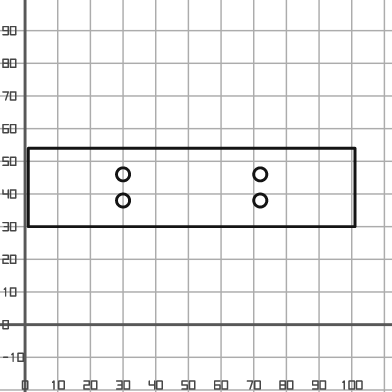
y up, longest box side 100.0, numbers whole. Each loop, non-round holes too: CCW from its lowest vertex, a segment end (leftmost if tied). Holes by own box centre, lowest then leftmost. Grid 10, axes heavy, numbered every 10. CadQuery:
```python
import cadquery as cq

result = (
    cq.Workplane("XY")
    .moveTo(1.0, 30.0)
    .lineTo(101.0, 30.0)
    .lineTo(101.0, 54.0)
    .lineTo(1.0, 54.0)
    .close()
    .moveTo(30.0, 38.0)
    .circle(2.0)
    .moveTo(72.0, 38.0)
    .circle(2.0)
    .moveTo(30.0, 46.0)
    .circle(2.0)
    .moveTo(72.0, 46.0)
    .circle(2.0)
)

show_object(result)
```